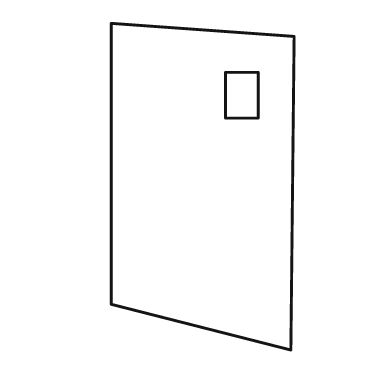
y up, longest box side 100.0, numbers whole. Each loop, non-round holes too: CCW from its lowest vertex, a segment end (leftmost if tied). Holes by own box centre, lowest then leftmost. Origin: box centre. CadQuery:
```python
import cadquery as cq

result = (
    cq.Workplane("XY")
    .moveTo(27.0, -50.0)
    .lineTo(28.0, 46.0)
    .lineTo(-28.0, 50.0)
    .lineTo(-28.0, -36.0)
    .close()
    .moveTo(7.0, 21.0)
    .lineTo(17.0, 21.0)
    .lineTo(17.0, 35.0)
    .lineTo(7.0, 35.0)
    .close()
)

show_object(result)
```